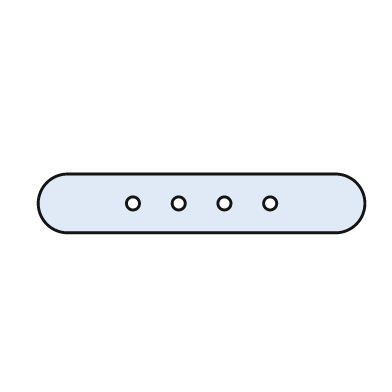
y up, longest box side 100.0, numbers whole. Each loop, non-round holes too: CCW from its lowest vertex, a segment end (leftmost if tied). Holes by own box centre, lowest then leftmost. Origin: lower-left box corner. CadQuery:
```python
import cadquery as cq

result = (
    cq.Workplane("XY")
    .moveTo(9.0, 0.0)
    .lineTo(91.0, 0.0)
    .threePointArc((100.0, 9.0), (91.0, 18.0))
    .lineTo(9.0, 18.0)
    .threePointArc((0.0, 9.0), (9.0, 0.0))
    .close()
    .moveTo(29.0, 9.0)
    .circle(2.0)
    .moveTo(43.0, 9.0)
    .circle(2.0)
    .moveTo(57.0, 9.0)
    .circle(2.0)
    .moveTo(71.0, 9.0)
    .circle(2.0)
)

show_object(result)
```